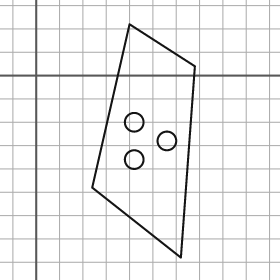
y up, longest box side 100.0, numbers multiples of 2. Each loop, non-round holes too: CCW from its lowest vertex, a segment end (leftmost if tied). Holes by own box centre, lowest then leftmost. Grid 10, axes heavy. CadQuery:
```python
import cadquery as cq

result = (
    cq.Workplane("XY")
    .moveTo(62.0, -78.0)
    .lineTo(68.0, 4.0)
    .lineTo(40.0, 22.0)
    .lineTo(24.0, -48.0)
    .close()
    .moveTo(42.0, -36.0)
    .circle(4.0)
    .moveTo(56.0, -28.0)
    .circle(4.0)
    .moveTo(42.0, -20.0)
    .circle(4.0)
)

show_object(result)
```